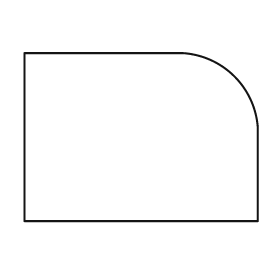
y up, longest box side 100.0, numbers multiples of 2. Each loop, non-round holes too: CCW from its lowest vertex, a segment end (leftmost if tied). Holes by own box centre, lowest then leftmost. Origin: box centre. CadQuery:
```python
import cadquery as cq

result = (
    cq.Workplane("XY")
    .moveTo(-50.0, -36.0)
    .lineTo(50.0, -36.0)
    .lineTo(50.0, 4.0)
    .threePointArc((40.0, 26.0), (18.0, 36.0))
    .lineTo(-50.0, 36.0)
    .close()
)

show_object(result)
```